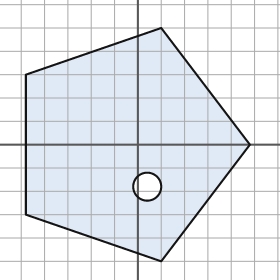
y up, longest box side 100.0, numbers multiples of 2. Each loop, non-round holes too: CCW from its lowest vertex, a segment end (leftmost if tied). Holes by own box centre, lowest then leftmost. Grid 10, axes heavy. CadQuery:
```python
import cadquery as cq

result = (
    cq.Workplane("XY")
    .moveTo(10.0, -50.0)
    .lineTo(48.0, 0.0)
    .lineTo(10.0, 50.0)
    .lineTo(-48.0, 30.0)
    .lineTo(-48.0, -30.0)
    .close()
    .moveTo(4.0, -18.0)
    .circle(6.0)
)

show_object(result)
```